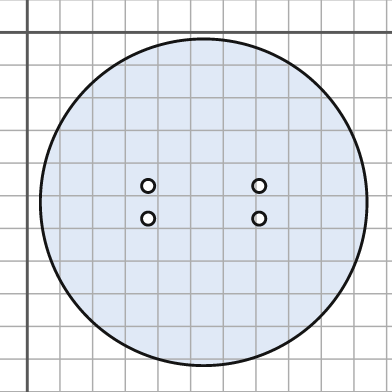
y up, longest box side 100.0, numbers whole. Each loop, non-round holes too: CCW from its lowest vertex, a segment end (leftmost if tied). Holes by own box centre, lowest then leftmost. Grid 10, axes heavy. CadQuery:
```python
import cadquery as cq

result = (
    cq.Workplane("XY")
    .moveTo(54.0, -52.0)
    .circle(50.0)
    .moveTo(37.0, -57.0)
    .circle(2.0)
    .moveTo(71.0, -57.0)
    .circle(2.0)
    .moveTo(37.0, -47.0)
    .circle(2.0)
    .moveTo(71.0, -47.0)
    .circle(2.0)
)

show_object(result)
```